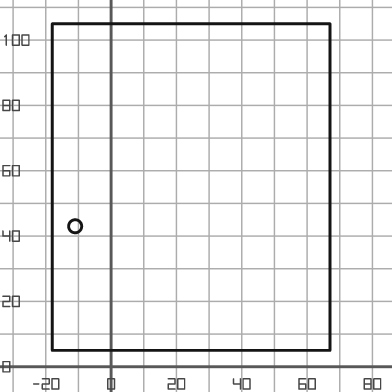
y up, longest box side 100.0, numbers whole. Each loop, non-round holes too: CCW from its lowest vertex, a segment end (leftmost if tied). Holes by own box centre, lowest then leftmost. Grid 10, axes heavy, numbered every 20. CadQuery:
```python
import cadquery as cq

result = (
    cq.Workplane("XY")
    .moveTo(-18.0, 5.0)
    .lineTo(67.0, 5.0)
    .lineTo(67.0, 105.0)
    .lineTo(-18.0, 105.0)
    .close()
    .moveTo(-11.0, 43.0)
    .circle(2.0)
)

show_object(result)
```